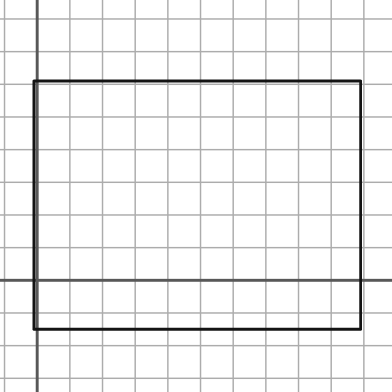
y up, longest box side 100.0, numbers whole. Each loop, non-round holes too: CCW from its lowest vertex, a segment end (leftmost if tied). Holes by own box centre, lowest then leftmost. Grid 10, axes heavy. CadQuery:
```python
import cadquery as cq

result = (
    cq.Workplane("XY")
    .moveTo(-1.0, -15.0)
    .lineTo(99.0, -15.0)
    .lineTo(99.0, 61.0)
    .lineTo(-1.0, 61.0)
    .close()
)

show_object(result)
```